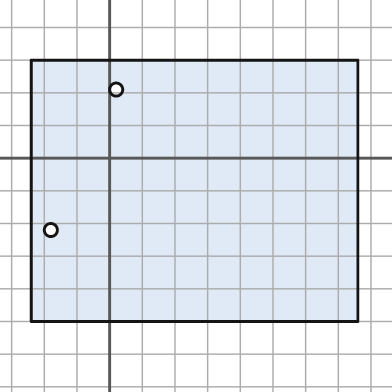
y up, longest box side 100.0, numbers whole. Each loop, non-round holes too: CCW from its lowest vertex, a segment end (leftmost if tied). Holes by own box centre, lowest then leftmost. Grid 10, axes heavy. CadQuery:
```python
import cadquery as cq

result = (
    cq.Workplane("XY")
    .moveTo(-24.0, -50.0)
    .lineTo(76.0, -50.0)
    .lineTo(76.0, 30.0)
    .lineTo(-24.0, 30.0)
    .close()
    .moveTo(-18.0, -22.0)
    .circle(2.0)
    .moveTo(2.0, 21.0)
    .circle(2.0)
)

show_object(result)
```